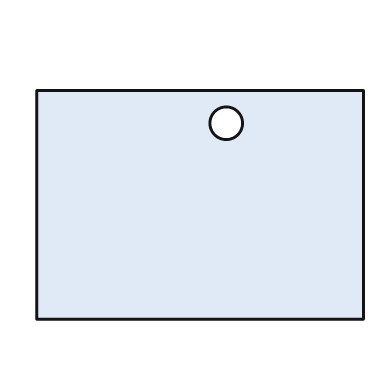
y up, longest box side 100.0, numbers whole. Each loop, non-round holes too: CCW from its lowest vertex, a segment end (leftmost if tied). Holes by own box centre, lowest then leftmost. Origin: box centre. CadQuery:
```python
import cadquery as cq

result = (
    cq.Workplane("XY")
    .moveTo(-50.0, -35.0)
    .lineTo(50.0, -35.0)
    .lineTo(50.0, 35.0)
    .lineTo(-50.0, 35.0)
    .close()
    .moveTo(8.0, 25.0)
    .circle(5.0)
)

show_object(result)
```